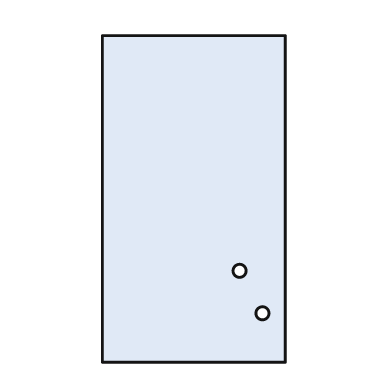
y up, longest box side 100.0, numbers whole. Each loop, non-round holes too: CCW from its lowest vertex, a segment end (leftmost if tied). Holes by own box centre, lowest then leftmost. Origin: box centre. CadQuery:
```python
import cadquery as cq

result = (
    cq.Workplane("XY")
    .moveTo(-28.0, -50.0)
    .lineTo(28.0, -50.0)
    .lineTo(28.0, 50.0)
    .lineTo(-28.0, 50.0)
    .close()
    .moveTo(21.0, -35.0)
    .circle(2.0)
    .moveTo(14.0, -22.0)
    .circle(2.0)
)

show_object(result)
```